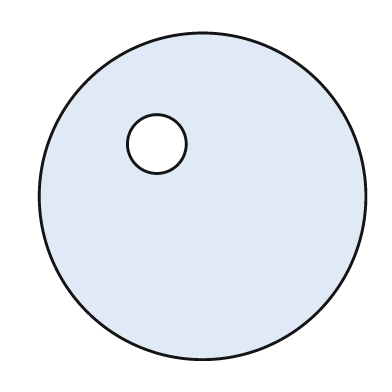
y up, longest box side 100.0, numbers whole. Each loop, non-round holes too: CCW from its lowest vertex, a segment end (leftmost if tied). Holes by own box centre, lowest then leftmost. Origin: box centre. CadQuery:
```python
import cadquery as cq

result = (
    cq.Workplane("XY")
    .moveTo(0.0, 0.0)
    .circle(50.0)
    .moveTo(-14.0, 16.0)
    .circle(9.0)
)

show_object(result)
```